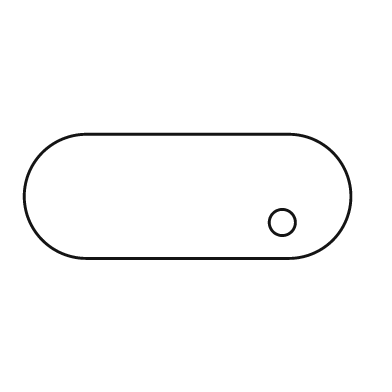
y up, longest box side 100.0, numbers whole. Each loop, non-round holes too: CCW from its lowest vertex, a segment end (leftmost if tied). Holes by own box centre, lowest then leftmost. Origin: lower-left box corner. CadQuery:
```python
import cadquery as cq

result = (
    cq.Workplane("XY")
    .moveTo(19.0, 0.0)
    .lineTo(81.0, 0.0)
    .threePointArc((100.0, 19.0), (81.0, 38.0))
    .lineTo(19.0, 38.0)
    .threePointArc((0.0, 19.0), (19.0, 0.0))
    .close()
    .moveTo(79.0, 11.0)
    .circle(4.0)
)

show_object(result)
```